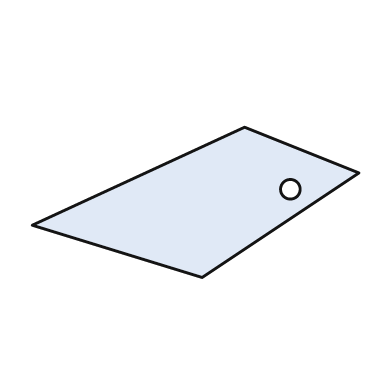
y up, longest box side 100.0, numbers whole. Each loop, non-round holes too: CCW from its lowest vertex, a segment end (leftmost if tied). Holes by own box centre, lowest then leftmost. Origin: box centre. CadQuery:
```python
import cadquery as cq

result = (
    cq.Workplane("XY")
    .moveTo(2.0, -23.0)
    .lineTo(50.0, 9.0)
    .lineTo(15.0, 23.0)
    .lineTo(-50.0, -7.0)
    .close()
    .moveTo(29.0, 4.0)
    .circle(3.0)
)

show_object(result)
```